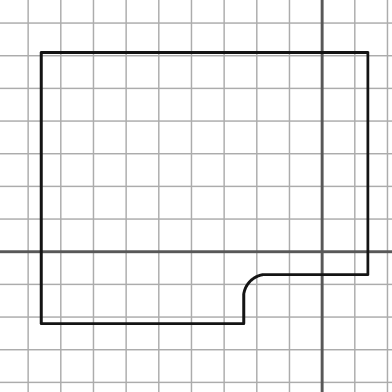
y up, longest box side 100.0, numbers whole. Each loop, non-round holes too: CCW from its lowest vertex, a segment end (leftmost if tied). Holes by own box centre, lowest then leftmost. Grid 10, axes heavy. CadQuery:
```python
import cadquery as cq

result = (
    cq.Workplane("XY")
    .moveTo(-86.0, -22.0)
    .lineTo(-24.0, -22.0)
    .lineTo(-24.0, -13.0)
    .threePointArc((-22.0, -9.0), (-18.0, -7.0))
    .lineTo(14.0, -7.0)
    .lineTo(14.0, 61.0)
    .lineTo(-86.0, 61.0)
    .close()
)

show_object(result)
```